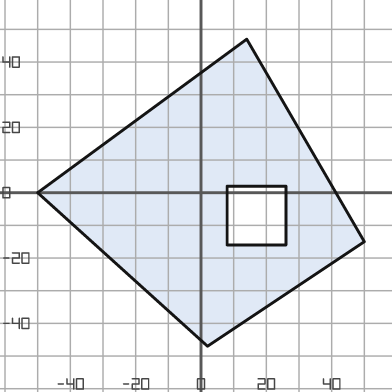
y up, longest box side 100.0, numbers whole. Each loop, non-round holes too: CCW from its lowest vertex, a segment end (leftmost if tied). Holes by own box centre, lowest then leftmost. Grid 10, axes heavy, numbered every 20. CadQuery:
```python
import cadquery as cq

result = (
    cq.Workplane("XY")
    .moveTo(2.0, -47.0)
    .lineTo(50.0, -15.0)
    .lineTo(14.0, 47.0)
    .lineTo(-50.0, 0.0)
    .close()
    .moveTo(8.0, -16.0)
    .lineTo(26.0, -16.0)
    .lineTo(26.0, 2.0)
    .lineTo(8.0, 2.0)
    .close()
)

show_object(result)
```